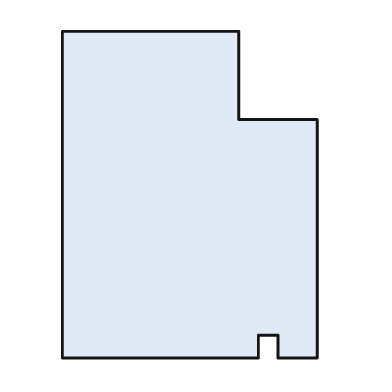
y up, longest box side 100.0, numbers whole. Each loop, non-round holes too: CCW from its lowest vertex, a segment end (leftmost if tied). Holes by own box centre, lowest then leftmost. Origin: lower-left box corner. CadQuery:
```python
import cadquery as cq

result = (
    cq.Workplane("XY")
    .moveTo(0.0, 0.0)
    .lineTo(60.0, 0.0)
    .lineTo(60.0, 7.0)
    .lineTo(66.0, 7.0)
    .lineTo(66.0, 0.0)
    .lineTo(78.0, 0.0)
    .lineTo(78.0, 73.0)
    .lineTo(54.0, 73.0)
    .lineTo(54.0, 100.0)
    .lineTo(0.0, 100.0)
    .close()
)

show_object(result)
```